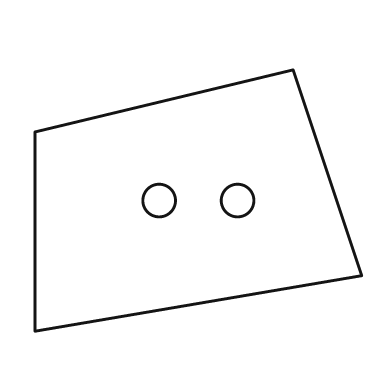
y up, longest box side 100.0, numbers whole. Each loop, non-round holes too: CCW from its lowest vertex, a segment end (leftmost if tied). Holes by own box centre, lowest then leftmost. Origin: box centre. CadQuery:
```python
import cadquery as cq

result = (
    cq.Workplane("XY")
    .moveTo(-50.0, -40.0)
    .lineTo(50.0, -23.0)
    .lineTo(29.0, 40.0)
    .lineTo(-50.0, 21.0)
    .close()
    .moveTo(-12.0, 0.0)
    .circle(5.0)
    .moveTo(12.0, 0.0)
    .circle(5.0)
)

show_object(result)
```